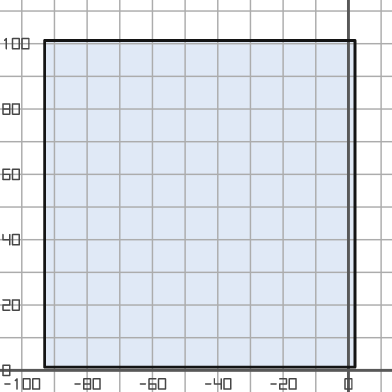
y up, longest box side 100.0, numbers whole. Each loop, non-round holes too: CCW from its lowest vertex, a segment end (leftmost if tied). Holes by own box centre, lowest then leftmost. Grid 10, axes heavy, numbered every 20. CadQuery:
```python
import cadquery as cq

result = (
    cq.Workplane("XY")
    .moveTo(-93.0, 1.0)
    .lineTo(2.0, 1.0)
    .lineTo(2.0, 101.0)
    .lineTo(-93.0, 101.0)
    .close()
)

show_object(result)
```